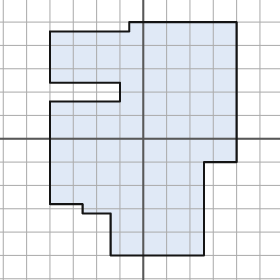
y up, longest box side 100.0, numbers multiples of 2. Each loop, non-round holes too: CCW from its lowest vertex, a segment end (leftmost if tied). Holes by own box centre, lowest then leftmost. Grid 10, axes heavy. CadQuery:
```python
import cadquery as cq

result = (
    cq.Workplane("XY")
    .moveTo(-14.0, -50.0)
    .lineTo(26.0, -50.0)
    .lineTo(26.0, -10.0)
    .lineTo(40.0, -10.0)
    .lineTo(40.0, 50.0)
    .lineTo(-6.0, 50.0)
    .lineTo(-6.0, 46.0)
    .lineTo(-40.0, 46.0)
    .lineTo(-40.0, 24.0)
    .lineTo(-10.0, 24.0)
    .lineTo(-10.0, 16.0)
    .lineTo(-40.0, 16.0)
    .lineTo(-40.0, -28.0)
    .lineTo(-26.0, -28.0)
    .lineTo(-26.0, -32.0)
    .lineTo(-14.0, -32.0)
    .close()
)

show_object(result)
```